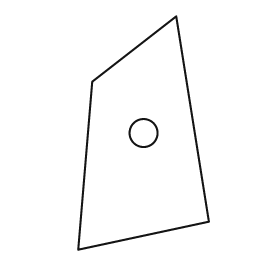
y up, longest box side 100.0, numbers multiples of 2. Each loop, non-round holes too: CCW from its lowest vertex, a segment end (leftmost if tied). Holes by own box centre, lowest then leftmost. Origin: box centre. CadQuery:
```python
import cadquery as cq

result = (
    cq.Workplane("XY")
    .moveTo(-28.0, -50.0)
    .lineTo(28.0, -38.0)
    .lineTo(14.0, 50.0)
    .lineTo(-22.0, 22.0)
    .close()
    .moveTo(0.0, 0.0)
    .circle(6.0)
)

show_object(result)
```